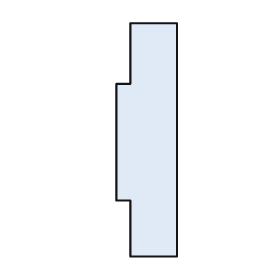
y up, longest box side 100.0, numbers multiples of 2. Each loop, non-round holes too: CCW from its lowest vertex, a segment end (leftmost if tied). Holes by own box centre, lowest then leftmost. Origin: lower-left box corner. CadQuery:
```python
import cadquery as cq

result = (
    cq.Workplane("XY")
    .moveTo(6.0, 0.0)
    .lineTo(26.0, 0.0)
    .lineTo(26.0, 100.0)
    .lineTo(6.0, 100.0)
    .lineTo(6.0, 74.0)
    .lineTo(0.0, 74.0)
    .lineTo(0.0, 24.0)
    .lineTo(6.0, 24.0)
    .close()
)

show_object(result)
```